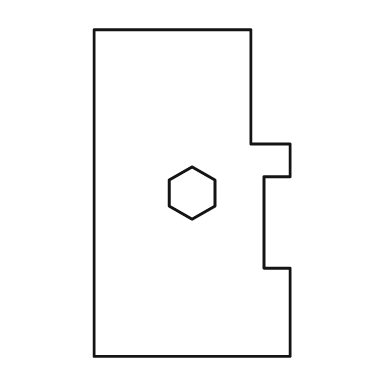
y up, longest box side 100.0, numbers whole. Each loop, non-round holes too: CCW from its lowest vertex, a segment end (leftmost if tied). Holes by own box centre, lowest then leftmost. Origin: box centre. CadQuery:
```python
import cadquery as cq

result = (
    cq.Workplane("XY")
    .moveTo(-30.0, -50.0)
    .lineTo(30.0, -50.0)
    .lineTo(30.0, -23.0)
    .lineTo(22.0, -23.0)
    .lineTo(22.0, 5.0)
    .lineTo(30.0, 5.0)
    .lineTo(30.0, 15.0)
    .lineTo(18.0, 15.0)
    .lineTo(18.0, 50.0)
    .lineTo(-30.0, 50.0)
    .close()
    .moveTo(0.0, -8.0)
    .lineTo(7.0, -4.0)
    .lineTo(7.0, 4.0)
    .lineTo(0.0, 8.0)
    .lineTo(-7.0, 4.0)
    .lineTo(-7.0, -4.0)
    .close()
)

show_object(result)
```